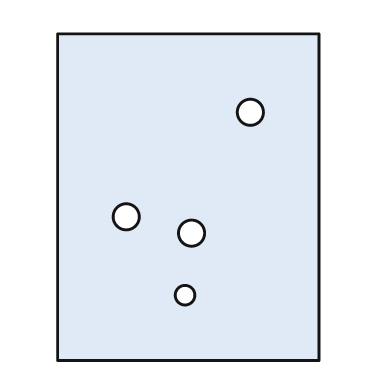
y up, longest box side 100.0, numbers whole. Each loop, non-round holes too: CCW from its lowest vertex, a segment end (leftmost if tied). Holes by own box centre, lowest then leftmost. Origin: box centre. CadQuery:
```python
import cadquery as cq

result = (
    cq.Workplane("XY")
    .moveTo(-40.0, -50.0)
    .lineTo(40.0, -50.0)
    .lineTo(40.0, 50.0)
    .lineTo(-40.0, 50.0)
    .close()
    .moveTo(-1.0, -30.0)
    .circle(3.0)
    .moveTo(1.0, -11.0)
    .circle(4.0)
    .moveTo(-19.0, -6.0)
    .circle(4.0)
    .moveTo(19.0, 26.0)
    .circle(4.0)
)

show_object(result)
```